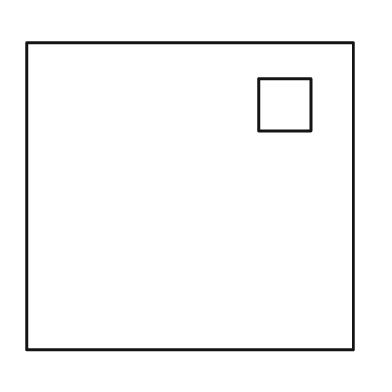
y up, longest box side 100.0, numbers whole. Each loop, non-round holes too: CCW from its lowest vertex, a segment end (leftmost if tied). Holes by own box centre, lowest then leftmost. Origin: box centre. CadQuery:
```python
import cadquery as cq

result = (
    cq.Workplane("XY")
    .moveTo(-50.0, -47.0)
    .lineTo(50.0, -47.0)
    .lineTo(50.0, 47.0)
    .lineTo(-50.0, 47.0)
    .close()
    .moveTo(21.0, 20.0)
    .lineTo(37.0, 20.0)
    .lineTo(37.0, 36.0)
    .lineTo(21.0, 36.0)
    .close()
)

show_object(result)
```